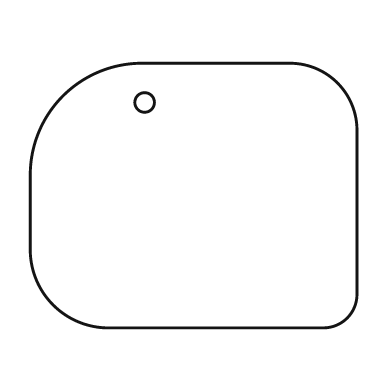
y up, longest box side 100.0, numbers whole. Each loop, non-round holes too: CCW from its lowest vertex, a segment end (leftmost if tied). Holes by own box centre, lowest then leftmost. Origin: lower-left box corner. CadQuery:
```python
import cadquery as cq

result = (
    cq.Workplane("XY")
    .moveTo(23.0, 0.0)
    .lineTo(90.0, 0.0)
    .threePointArc((97.0, 3.0), (100.0, 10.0))
    .lineTo(100.0, 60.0)
    .threePointArc((94.0, 75.0), (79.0, 81.0))
    .lineTo(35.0, 81.0)
    .threePointArc((10.0, 71.0), (0.0, 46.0))
    .lineTo(0.0, 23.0)
    .threePointArc((7.0, 7.0), (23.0, 0.0))
    .close()
    .moveTo(35.0, 69.0)
    .circle(3.0)
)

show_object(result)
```